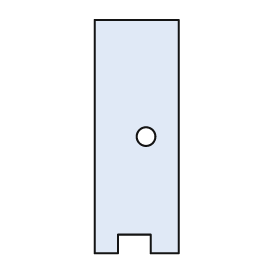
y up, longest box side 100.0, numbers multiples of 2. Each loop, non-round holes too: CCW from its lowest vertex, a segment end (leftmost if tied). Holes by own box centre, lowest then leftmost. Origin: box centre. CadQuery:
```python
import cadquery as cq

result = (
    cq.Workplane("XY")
    .moveTo(-18.0, -50.0)
    .lineTo(-8.0, -50.0)
    .lineTo(-8.0, -42.0)
    .lineTo(6.0, -42.0)
    .lineTo(6.0, -50.0)
    .lineTo(18.0, -50.0)
    .lineTo(18.0, 50.0)
    .lineTo(-18.0, 50.0)
    .close()
    .moveTo(4.0, 0.0)
    .circle(4.0)
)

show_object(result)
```